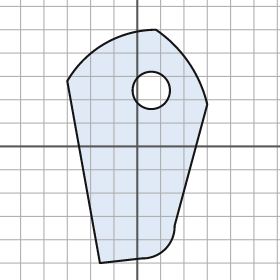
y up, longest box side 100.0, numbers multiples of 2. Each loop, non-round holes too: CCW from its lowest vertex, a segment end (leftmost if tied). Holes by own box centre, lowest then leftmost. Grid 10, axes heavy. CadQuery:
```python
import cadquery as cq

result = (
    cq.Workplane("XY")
    .moveTo(-16.0, -50.0)
    .lineTo(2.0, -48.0)
    .threePointArc((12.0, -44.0), (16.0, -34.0))
    .lineTo(30.0, 18.0)
    .threePointArc((22.0, 36.0), (8.0, 50.0))
    .threePointArc((-14.0, 44.0), (-30.0, 28.0))
    .close()
    .moveTo(6.0, 24.0)
    .circle(8.0)
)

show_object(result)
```